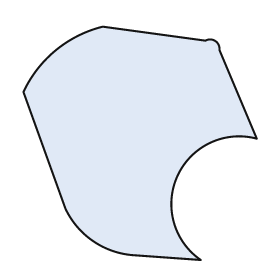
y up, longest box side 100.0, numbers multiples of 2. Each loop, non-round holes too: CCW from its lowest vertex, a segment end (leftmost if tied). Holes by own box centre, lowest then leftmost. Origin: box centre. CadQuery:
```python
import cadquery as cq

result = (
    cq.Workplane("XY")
    .moveTo(26.0, -50.0)
    .threePointArc((16.0, -14.0), (50.0, 2.0))
    .lineTo(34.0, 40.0)
    .threePointArc((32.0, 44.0), (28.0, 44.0))
    .lineTo(-16.0, 50.0)
    .threePointArc((-36.0, 40.0), (-50.0, 22.0))
    .lineTo(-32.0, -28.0)
    .threePointArc((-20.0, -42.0), (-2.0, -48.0))
    .close()
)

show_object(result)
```